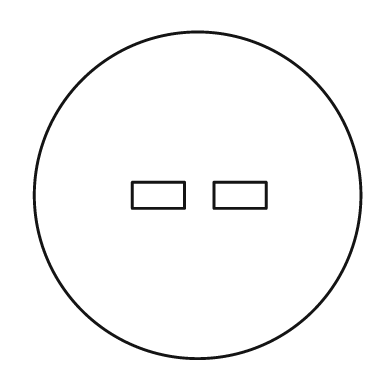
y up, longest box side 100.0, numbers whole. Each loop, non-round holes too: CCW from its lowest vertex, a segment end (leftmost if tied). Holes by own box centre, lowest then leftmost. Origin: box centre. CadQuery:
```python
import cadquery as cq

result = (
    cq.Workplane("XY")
    .moveTo(0.0, 0.0)
    .circle(50.0)
    .moveTo(-20.0, -4.0)
    .lineTo(-4.0, -4.0)
    .lineTo(-4.0, 4.0)
    .lineTo(-20.0, 4.0)
    .close()
    .moveTo(5.0, -4.0)
    .lineTo(21.0, -4.0)
    .lineTo(21.0, 4.0)
    .lineTo(5.0, 4.0)
    .close()
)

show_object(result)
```